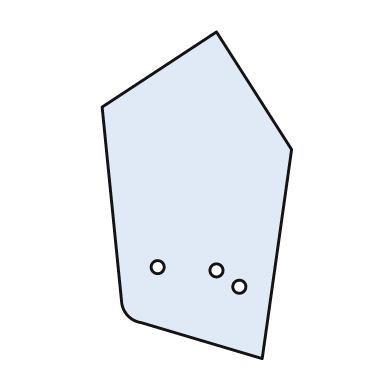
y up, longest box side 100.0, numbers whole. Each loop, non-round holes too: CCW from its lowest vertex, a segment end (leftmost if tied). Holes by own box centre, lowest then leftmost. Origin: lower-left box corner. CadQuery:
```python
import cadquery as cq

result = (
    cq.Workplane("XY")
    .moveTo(49.0, 0.0)
    .lineTo(58.0, 64.0)
    .lineTo(35.0, 100.0)
    .lineTo(0.0, 77.0)
    .lineTo(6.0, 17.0)
    .threePointArc((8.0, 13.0), (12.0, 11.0))
    .close()
    .moveTo(42.0, 22.0)
    .circle(2.0)
    .moveTo(35.0, 27.0)
    .circle(2.0)
    .moveTo(17.0, 28.0)
    .circle(2.0)
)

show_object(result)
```